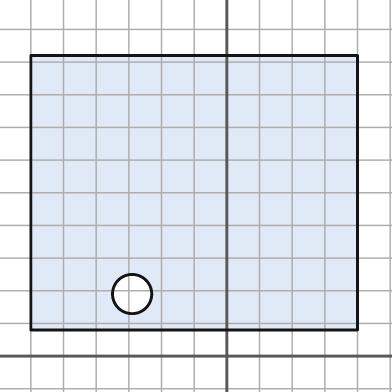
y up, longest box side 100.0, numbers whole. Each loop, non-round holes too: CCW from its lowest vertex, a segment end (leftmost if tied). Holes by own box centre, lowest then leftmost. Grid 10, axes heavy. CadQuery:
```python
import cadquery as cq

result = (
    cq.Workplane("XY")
    .moveTo(-60.0, 8.0)
    .lineTo(40.0, 8.0)
    .lineTo(40.0, 92.0)
    .lineTo(-60.0, 92.0)
    .close()
    .moveTo(-29.0, 19.0)
    .circle(6.0)
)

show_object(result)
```